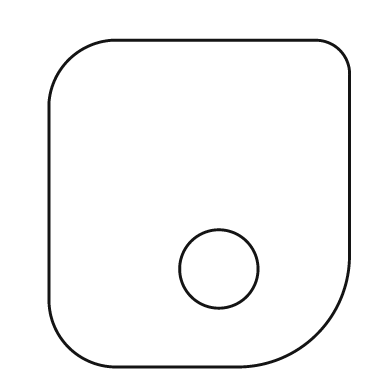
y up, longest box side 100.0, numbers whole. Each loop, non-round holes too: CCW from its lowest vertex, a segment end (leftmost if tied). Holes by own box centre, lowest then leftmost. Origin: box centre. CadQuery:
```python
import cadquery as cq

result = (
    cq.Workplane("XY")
    .moveTo(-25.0, -50.0)
    .lineTo(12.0, -50.0)
    .threePointArc((36.0, -40.0), (46.0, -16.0))
    .lineTo(46.0, 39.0)
    .threePointArc((43.0, 47.0), (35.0, 50.0))
    .lineTo(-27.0, 50.0)
    .threePointArc((-40.0, 44.0), (-46.0, 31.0))
    .lineTo(-46.0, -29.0)
    .threePointArc((-40.0, -44.0), (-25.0, -50.0))
    .close()
    .moveTo(6.0, -20.0)
    .circle(12.0)
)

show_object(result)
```